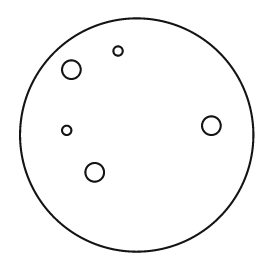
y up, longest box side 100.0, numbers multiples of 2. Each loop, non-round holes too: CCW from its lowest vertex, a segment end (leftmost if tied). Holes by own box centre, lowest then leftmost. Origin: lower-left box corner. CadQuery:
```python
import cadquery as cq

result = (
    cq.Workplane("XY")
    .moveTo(50.0, 50.0)
    .circle(50.0)
    .moveTo(32.0, 34.0)
    .circle(4.0)
    .moveTo(20.0, 52.0)
    .circle(2.0)
    .moveTo(82.0, 54.0)
    .circle(4.0)
    .moveTo(22.0, 78.0)
    .circle(4.0)
    .moveTo(42.0, 86.0)
    .circle(2.0)
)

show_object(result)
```